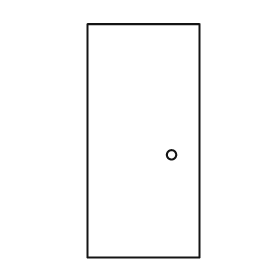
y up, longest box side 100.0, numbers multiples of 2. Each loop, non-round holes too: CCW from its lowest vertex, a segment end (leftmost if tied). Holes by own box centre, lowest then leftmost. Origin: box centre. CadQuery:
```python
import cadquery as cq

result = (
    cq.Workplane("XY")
    .moveTo(-24.0, -50.0)
    .lineTo(24.0, -50.0)
    .lineTo(24.0, 50.0)
    .lineTo(-24.0, 50.0)
    .close()
    .moveTo(12.0, -6.0)
    .circle(2.0)
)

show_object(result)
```